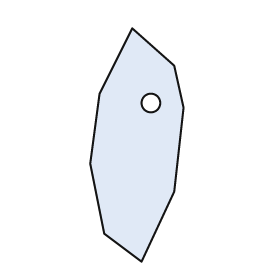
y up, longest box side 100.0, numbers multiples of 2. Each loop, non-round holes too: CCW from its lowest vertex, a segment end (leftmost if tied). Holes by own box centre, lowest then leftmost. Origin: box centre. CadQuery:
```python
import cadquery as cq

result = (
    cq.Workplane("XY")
    .moveTo(2.0, -50.0)
    .lineTo(16.0, -20.0)
    .lineTo(20.0, 16.0)
    .lineTo(16.0, 34.0)
    .lineTo(-2.0, 50.0)
    .lineTo(-16.0, 22.0)
    .lineTo(-20.0, -8.0)
    .lineTo(-14.0, -38.0)
    .close()
    .moveTo(6.0, 18.0)
    .circle(4.0)
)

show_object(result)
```